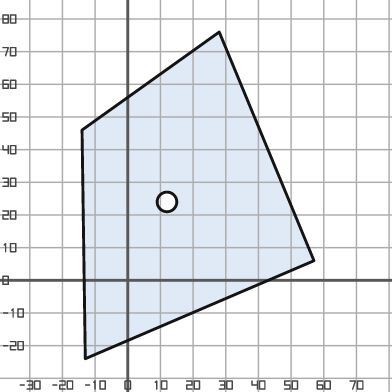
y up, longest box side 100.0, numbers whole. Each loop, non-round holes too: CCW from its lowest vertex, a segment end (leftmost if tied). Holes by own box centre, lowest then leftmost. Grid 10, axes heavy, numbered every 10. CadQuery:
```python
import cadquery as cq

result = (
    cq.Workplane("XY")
    .moveTo(-13.0, -24.0)
    .lineTo(57.0, 6.0)
    .lineTo(28.0, 76.0)
    .lineTo(-14.0, 46.0)
    .close()
    .moveTo(12.0, 24.0)
    .circle(3.0)
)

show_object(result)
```